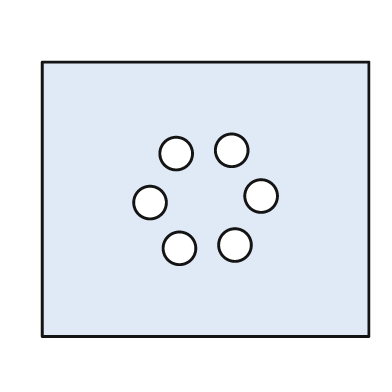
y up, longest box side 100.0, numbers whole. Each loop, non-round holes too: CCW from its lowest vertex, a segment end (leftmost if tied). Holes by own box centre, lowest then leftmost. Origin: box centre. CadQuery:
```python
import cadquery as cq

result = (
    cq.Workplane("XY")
    .moveTo(-50.0, -42.0)
    .lineTo(50.0, -42.0)
    .lineTo(50.0, 42.0)
    .lineTo(-50.0, 42.0)
    .close()
    .moveTo(-8.0, -15.0)
    .circle(5.0)
    .moveTo(9.0, -14.0)
    .circle(5.0)
    .moveTo(-17.0, -1.0)
    .circle(5.0)
    .moveTo(17.0, 1.0)
    .circle(5.0)
    .moveTo(-9.0, 14.0)
    .circle(5.0)
    .moveTo(8.0, 15.0)
    .circle(5.0)
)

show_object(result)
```